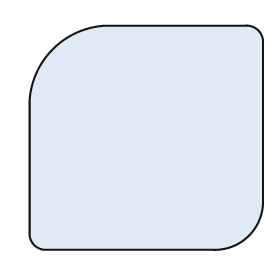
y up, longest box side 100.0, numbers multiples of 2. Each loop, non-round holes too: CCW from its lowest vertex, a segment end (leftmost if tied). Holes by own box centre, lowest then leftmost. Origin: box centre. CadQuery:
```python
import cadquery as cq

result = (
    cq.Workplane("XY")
    .moveTo(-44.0, -48.0)
    .lineTo(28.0, -48.0)
    .threePointArc((44.0, -42.0), (50.0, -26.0))
    .lineTo(50.0, 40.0)
    .threePointArc((48.0, 46.0), (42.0, 48.0))
    .lineTo(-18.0, 48.0)
    .threePointArc((-40.0, 38.0), (-50.0, 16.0))
    .lineTo(-50.0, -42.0)
    .threePointArc((-48.0, -46.0), (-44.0, -48.0))
    .close()
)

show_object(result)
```